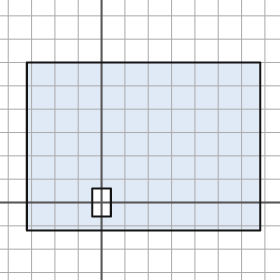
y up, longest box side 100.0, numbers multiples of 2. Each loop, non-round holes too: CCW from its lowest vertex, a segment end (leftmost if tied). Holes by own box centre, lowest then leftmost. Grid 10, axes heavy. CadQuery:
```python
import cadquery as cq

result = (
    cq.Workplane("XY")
    .moveTo(-32.0, -12.0)
    .lineTo(68.0, -12.0)
    .lineTo(68.0, 60.0)
    .lineTo(-32.0, 60.0)
    .close()
    .moveTo(-4.0, -6.0)
    .lineTo(4.0, -6.0)
    .lineTo(4.0, 6.0)
    .lineTo(-4.0, 6.0)
    .close()
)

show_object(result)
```